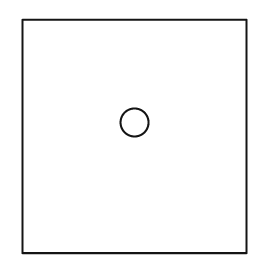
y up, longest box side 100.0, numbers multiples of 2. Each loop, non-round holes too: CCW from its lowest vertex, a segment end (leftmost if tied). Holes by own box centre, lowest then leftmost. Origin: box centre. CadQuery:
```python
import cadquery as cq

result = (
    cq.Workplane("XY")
    .moveTo(-48.0, -50.0)
    .lineTo(48.0, -50.0)
    .lineTo(48.0, 50.0)
    .lineTo(-48.0, 50.0)
    .close()
    .moveTo(0.0, 6.0)
    .circle(6.0)
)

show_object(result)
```